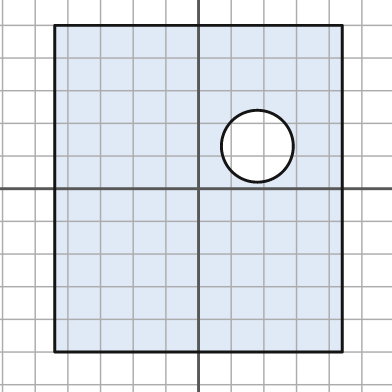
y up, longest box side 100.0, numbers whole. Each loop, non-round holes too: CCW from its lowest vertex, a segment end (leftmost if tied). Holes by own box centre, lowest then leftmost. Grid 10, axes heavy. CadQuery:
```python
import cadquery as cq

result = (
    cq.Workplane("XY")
    .moveTo(-44.0, -50.0)
    .lineTo(44.0, -50.0)
    .lineTo(44.0, 50.0)
    .lineTo(-44.0, 50.0)
    .close()
    .moveTo(18.0, 13.0)
    .circle(11.0)
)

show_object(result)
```